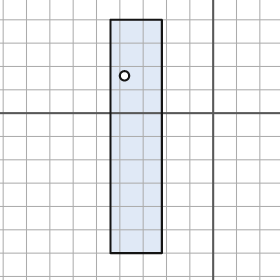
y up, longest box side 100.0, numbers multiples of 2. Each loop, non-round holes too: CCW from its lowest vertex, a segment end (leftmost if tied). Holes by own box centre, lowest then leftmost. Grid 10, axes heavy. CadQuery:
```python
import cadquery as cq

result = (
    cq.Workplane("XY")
    .moveTo(-44.0, -60.0)
    .lineTo(-22.0, -60.0)
    .lineTo(-22.0, 40.0)
    .lineTo(-44.0, 40.0)
    .close()
    .moveTo(-38.0, 16.0)
    .circle(2.0)
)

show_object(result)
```